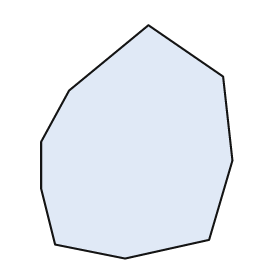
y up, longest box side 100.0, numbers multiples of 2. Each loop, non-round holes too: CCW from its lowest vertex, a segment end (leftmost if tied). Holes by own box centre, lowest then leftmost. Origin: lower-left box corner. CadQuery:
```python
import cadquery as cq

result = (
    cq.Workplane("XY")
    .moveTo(36.0, 0.0)
    .lineTo(72.0, 8.0)
    .lineTo(82.0, 42.0)
    .lineTo(78.0, 78.0)
    .lineTo(46.0, 100.0)
    .lineTo(12.0, 72.0)
    .lineTo(0.0, 50.0)
    .lineTo(0.0, 30.0)
    .lineTo(6.0, 6.0)
    .close()
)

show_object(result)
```